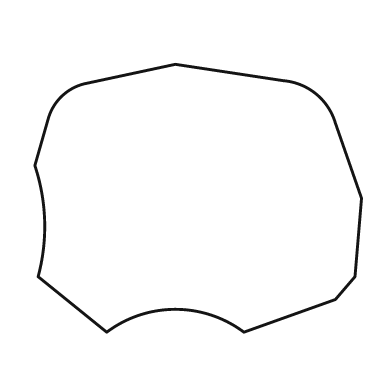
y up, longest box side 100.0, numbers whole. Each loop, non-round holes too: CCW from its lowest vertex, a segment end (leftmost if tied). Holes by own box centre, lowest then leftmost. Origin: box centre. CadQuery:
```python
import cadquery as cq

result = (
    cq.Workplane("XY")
    .moveTo(-28.0, -41.0)
    .threePointArc((-7.0, -34.0), (14.0, -41.0))
    .lineTo(42.0, -31.0)
    .lineTo(48.0, -24.0)
    .lineTo(50.0, 0.0)
    .lineTo(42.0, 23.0)
    .threePointArc((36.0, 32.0), (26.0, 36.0))
    .lineTo(-7.0, 41.0)
    .lineTo(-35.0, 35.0)
    .threePointArc((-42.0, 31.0), (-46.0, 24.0))
    .lineTo(-50.0, 10.0)
    .threePointArc((-47.0, -7.0), (-49.0, -24.0))
    .close()
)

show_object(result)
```